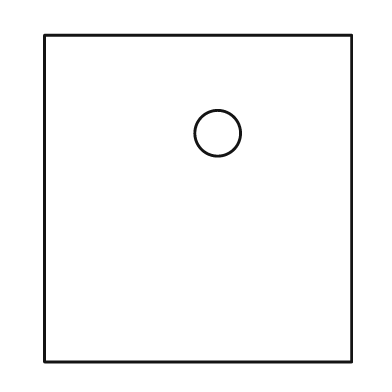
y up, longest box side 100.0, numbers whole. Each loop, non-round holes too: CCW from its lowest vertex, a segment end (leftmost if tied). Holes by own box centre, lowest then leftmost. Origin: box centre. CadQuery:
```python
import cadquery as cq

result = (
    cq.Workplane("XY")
    .moveTo(-47.0, -50.0)
    .lineTo(47.0, -50.0)
    .lineTo(47.0, 50.0)
    .lineTo(-47.0, 50.0)
    .close()
    .moveTo(6.0, 20.0)
    .circle(7.0)
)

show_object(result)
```